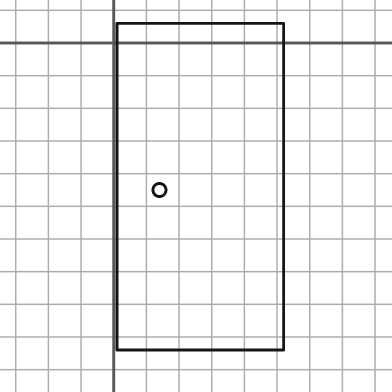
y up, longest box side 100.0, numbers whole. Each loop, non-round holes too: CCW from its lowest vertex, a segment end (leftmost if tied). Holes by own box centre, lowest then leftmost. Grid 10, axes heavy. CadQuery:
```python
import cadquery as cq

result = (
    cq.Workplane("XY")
    .moveTo(1.0, -94.0)
    .lineTo(52.0, -94.0)
    .lineTo(52.0, 6.0)
    .lineTo(1.0, 6.0)
    .close()
    .moveTo(14.0, -45.0)
    .circle(2.0)
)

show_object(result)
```